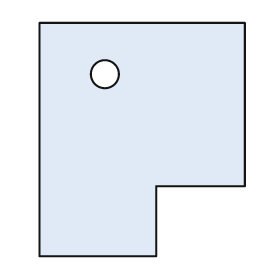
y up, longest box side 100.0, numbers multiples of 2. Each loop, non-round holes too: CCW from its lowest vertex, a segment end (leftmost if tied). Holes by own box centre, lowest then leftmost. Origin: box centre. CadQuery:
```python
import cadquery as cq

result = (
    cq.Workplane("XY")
    .moveTo(-44.0, -50.0)
    .lineTo(6.0, -50.0)
    .lineTo(6.0, -20.0)
    .lineTo(44.0, -20.0)
    .lineTo(44.0, 50.0)
    .lineTo(-44.0, 50.0)
    .close()
    .moveTo(-16.0, 28.0)
    .circle(6.0)
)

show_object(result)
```